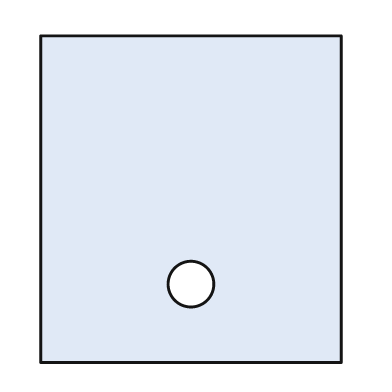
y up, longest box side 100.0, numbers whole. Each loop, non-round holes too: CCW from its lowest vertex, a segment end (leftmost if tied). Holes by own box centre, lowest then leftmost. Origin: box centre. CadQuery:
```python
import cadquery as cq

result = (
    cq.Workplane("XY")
    .moveTo(-46.0, -50.0)
    .lineTo(46.0, -50.0)
    .lineTo(46.0, 50.0)
    .lineTo(-46.0, 50.0)
    .close()
    .moveTo(0.0, -26.0)
    .circle(7.0)
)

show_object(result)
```